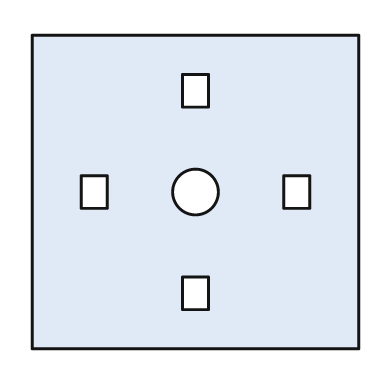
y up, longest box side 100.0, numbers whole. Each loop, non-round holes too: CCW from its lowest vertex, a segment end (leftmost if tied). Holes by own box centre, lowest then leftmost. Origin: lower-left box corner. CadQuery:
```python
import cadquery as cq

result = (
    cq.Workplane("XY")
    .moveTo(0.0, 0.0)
    .lineTo(100.0, 0.0)
    .lineTo(100.0, 96.0)
    .lineTo(0.0, 96.0)
    .close()
    .moveTo(46.0, 12.0)
    .lineTo(54.0, 12.0)
    .lineTo(54.0, 22.0)
    .lineTo(46.0, 22.0)
    .close()
    .moveTo(15.0, 43.0)
    .lineTo(23.0, 43.0)
    .lineTo(23.0, 53.0)
    .lineTo(15.0, 53.0)
    .close()
    .moveTo(50.0, 48.0)
    .circle(7.0)
    .moveTo(77.0, 43.0)
    .lineTo(85.0, 43.0)
    .lineTo(85.0, 53.0)
    .lineTo(77.0, 53.0)
    .close()
    .moveTo(46.0, 74.0)
    .lineTo(54.0, 74.0)
    .lineTo(54.0, 84.0)
    .lineTo(46.0, 84.0)
    .close()
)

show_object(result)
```